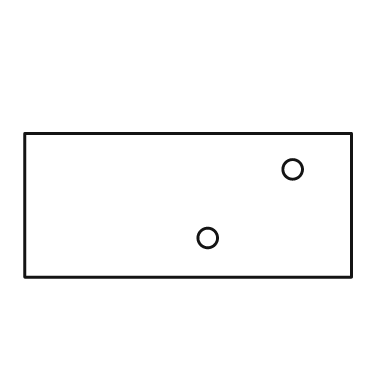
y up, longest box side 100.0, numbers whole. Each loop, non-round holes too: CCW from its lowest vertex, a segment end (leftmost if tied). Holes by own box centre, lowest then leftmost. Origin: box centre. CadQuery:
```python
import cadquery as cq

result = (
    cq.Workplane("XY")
    .moveTo(-50.0, -22.0)
    .lineTo(50.0, -22.0)
    .lineTo(50.0, 22.0)
    .lineTo(-50.0, 22.0)
    .close()
    .moveTo(6.0, -10.0)
    .circle(3.0)
    .moveTo(32.0, 11.0)
    .circle(3.0)
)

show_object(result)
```